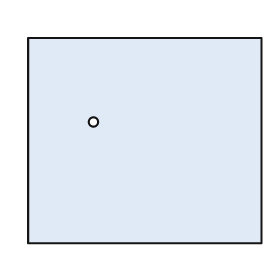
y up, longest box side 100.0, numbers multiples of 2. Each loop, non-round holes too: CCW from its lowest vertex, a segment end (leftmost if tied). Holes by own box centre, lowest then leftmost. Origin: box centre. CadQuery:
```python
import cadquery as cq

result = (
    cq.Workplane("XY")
    .moveTo(-50.0, -44.0)
    .lineTo(50.0, -44.0)
    .lineTo(50.0, 44.0)
    .lineTo(-50.0, 44.0)
    .close()
    .moveTo(-22.0, 8.0)
    .circle(2.0)
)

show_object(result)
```